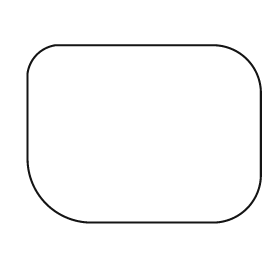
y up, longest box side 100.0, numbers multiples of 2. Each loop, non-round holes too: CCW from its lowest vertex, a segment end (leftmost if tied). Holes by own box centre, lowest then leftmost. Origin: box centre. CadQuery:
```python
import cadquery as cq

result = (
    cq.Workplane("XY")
    .moveTo(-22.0, -38.0)
    .lineTo(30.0, -38.0)
    .threePointArc((44.0, -32.0), (50.0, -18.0))
    .lineTo(50.0, 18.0)
    .threePointArc((44.0, 32.0), (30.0, 38.0))
    .lineTo(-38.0, 38.0)
    .threePointArc((-46.0, 34.0), (-50.0, 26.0))
    .lineTo(-50.0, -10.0)
    .threePointArc((-42.0, -30.0), (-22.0, -38.0))
    .close()
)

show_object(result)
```